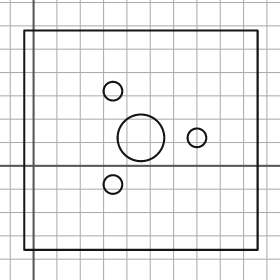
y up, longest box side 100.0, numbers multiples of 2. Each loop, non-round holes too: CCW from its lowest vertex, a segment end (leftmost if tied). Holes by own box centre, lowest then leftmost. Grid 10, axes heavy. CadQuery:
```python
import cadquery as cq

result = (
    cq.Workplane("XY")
    .moveTo(-4.0, -36.0)
    .lineTo(96.0, -36.0)
    .lineTo(96.0, 58.0)
    .lineTo(-4.0, 58.0)
    .close()
    .moveTo(34.0, -8.0)
    .circle(4.0)
    .moveTo(46.0, 12.0)
    .circle(10.0)
    .moveTo(70.0, 12.0)
    .circle(4.0)
    .moveTo(34.0, 32.0)
    .circle(4.0)
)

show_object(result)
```